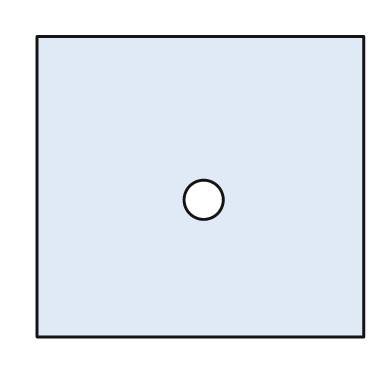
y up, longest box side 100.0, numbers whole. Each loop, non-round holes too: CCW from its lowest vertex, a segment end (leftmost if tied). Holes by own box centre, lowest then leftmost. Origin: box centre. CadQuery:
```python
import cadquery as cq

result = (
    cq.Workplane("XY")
    .moveTo(-50.0, -46.0)
    .lineTo(50.0, -46.0)
    .lineTo(50.0, 46.0)
    .lineTo(-50.0, 46.0)
    .close()
    .moveTo(1.0, -4.0)
    .circle(6.0)
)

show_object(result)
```